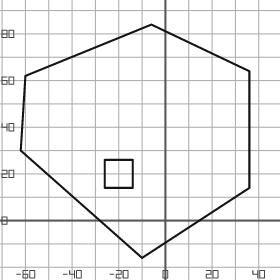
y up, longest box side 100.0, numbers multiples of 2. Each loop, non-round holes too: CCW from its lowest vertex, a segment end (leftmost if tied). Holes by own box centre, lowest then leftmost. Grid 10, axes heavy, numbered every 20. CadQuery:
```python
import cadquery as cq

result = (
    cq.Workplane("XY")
    .moveTo(-10.0, -16.0)
    .lineTo(36.0, 14.0)
    .lineTo(36.0, 64.0)
    .lineTo(-6.0, 84.0)
    .lineTo(-60.0, 62.0)
    .lineTo(-62.0, 30.0)
    .close()
    .moveTo(-26.0, 14.0)
    .lineTo(-14.0, 14.0)
    .lineTo(-14.0, 26.0)
    .lineTo(-26.0, 26.0)
    .close()
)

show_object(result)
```